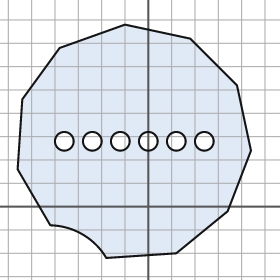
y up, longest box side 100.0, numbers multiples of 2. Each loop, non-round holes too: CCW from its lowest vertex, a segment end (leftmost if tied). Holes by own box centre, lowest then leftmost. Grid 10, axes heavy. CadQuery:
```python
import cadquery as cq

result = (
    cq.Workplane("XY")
    .moveTo(-18.0, -22.0)
    .lineTo(12.0, -20.0)
    .lineTo(34.0, -2.0)
    .lineTo(44.0, 24.0)
    .lineTo(38.0, 52.0)
    .lineTo(18.0, 72.0)
    .lineTo(-10.0, 78.0)
    .lineTo(-38.0, 68.0)
    .lineTo(-54.0, 46.0)
    .lineTo(-56.0, 16.0)
    .lineTo(-42.0, -8.0)
    .threePointArc((-28.0, -12.0), (-18.0, -22.0))
    .close()
    .moveTo(-36.0, 28.0)
    .circle(4.0)
    .moveTo(-24.0, 28.0)
    .circle(4.0)
    .moveTo(-12.0, 28.0)
    .circle(4.0)
    .moveTo(0.0, 28.0)
    .circle(4.0)
    .moveTo(12.0, 28.0)
    .circle(4.0)
    .moveTo(24.0, 28.0)
    .circle(4.0)
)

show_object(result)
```